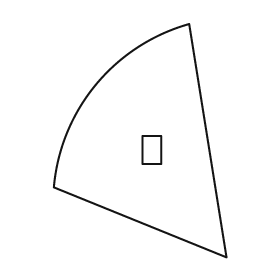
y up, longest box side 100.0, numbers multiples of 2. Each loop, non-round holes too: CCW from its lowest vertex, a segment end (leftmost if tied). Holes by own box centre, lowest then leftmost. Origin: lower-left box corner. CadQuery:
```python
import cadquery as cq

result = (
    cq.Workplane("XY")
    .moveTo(74.0, 0.0)
    .lineTo(58.0, 100.0)
    .threePointArc((18.0, 74.0), (0.0, 30.0))
    .close()
    .moveTo(38.0, 40.0)
    .lineTo(46.0, 40.0)
    .lineTo(46.0, 52.0)
    .lineTo(38.0, 52.0)
    .close()
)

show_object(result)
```